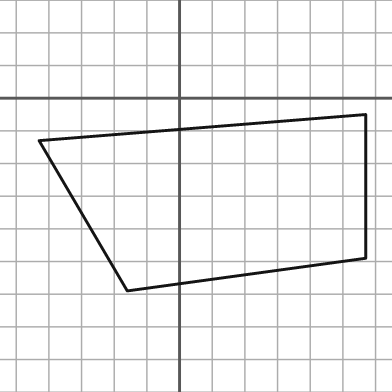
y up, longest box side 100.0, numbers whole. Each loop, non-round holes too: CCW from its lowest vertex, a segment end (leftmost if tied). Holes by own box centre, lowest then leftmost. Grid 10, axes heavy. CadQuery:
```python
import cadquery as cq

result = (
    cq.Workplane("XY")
    .moveTo(-16.0, -59.0)
    .lineTo(57.0, -49.0)
    .lineTo(57.0, -5.0)
    .lineTo(-43.0, -13.0)
    .close()
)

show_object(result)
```